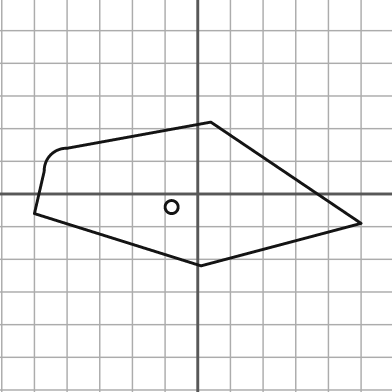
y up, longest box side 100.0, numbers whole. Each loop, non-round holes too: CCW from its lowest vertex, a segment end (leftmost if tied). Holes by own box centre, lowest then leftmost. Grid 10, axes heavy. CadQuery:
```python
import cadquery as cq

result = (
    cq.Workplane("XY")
    .moveTo(1.0, -22.0)
    .lineTo(50.0, -9.0)
    .lineTo(4.0, 22.0)
    .lineTo(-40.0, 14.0)
    .threePointArc((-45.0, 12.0), (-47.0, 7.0))
    .lineTo(-50.0, -6.0)
    .close()
    .moveTo(-8.0, -4.0)
    .circle(2.0)
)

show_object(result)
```